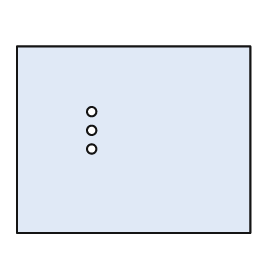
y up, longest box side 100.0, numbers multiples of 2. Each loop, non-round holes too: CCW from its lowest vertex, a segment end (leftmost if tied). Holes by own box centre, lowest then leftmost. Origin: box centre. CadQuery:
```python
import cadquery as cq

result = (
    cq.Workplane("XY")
    .moveTo(-50.0, -40.0)
    .lineTo(50.0, -40.0)
    .lineTo(50.0, 40.0)
    .lineTo(-50.0, 40.0)
    .close()
    .moveTo(-18.0, -4.0)
    .circle(2.0)
    .moveTo(-18.0, 4.0)
    .circle(2.0)
    .moveTo(-18.0, 12.0)
    .circle(2.0)
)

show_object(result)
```